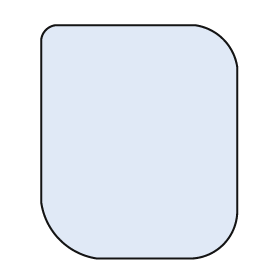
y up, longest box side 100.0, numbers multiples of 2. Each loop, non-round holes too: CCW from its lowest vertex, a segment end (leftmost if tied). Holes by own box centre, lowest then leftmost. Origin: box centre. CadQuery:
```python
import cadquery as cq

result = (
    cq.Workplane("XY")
    .moveTo(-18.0, -50.0)
    .lineTo(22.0, -50.0)
    .threePointArc((36.0, -44.0), (42.0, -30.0))
    .lineTo(42.0, 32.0)
    .threePointArc((36.0, 44.0), (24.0, 50.0))
    .lineTo(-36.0, 50.0)
    .threePointArc((-40.0, 48.0), (-42.0, 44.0))
    .lineTo(-42.0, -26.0)
    .threePointArc((-34.0, -42.0), (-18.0, -50.0))
    .close()
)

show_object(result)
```